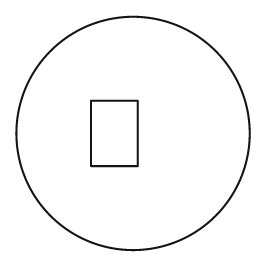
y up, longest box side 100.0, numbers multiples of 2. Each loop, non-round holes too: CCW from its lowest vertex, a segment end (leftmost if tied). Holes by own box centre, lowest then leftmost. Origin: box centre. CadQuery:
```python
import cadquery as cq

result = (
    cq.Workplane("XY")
    .moveTo(0.0, 0.0)
    .circle(50.0)
    .moveTo(-18.0, -14.0)
    .lineTo(2.0, -14.0)
    .lineTo(2.0, 14.0)
    .lineTo(-18.0, 14.0)
    .close()
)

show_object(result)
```